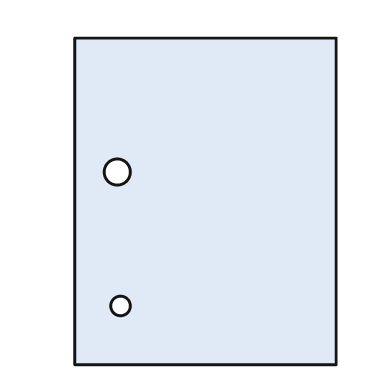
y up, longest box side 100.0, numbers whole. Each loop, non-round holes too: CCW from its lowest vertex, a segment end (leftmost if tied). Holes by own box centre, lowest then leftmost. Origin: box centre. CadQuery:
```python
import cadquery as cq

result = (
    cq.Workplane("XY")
    .moveTo(-40.0, -50.0)
    .lineTo(40.0, -50.0)
    .lineTo(40.0, 50.0)
    .lineTo(-40.0, 50.0)
    .close()
    .moveTo(-26.0, -32.0)
    .circle(3.0)
    .moveTo(-27.0, 9.0)
    .circle(4.0)
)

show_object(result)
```